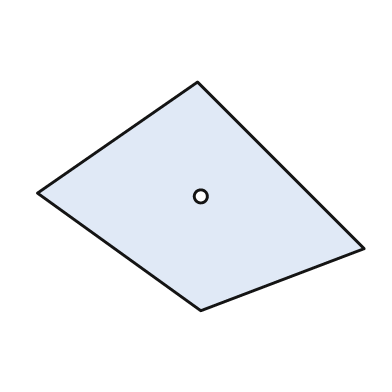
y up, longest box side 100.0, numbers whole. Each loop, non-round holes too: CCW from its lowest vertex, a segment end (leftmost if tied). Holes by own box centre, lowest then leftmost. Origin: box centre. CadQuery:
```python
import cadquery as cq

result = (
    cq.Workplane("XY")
    .moveTo(0.0, -35.0)
    .lineTo(50.0, -16.0)
    .lineTo(-1.0, 35.0)
    .lineTo(-50.0, 1.0)
    .close()
    .moveTo(0.0, 0.0)
    .circle(2.0)
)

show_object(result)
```